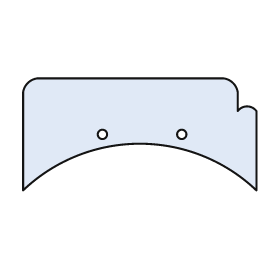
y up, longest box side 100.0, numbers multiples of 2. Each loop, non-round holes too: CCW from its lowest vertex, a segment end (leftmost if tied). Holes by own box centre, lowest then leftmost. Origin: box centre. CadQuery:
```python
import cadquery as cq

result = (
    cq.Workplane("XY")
    .moveTo(-50.0, -24.0)
    .threePointArc((0.0, -4.0), (50.0, -24.0))
    .lineTo(50.0, 10.0)
    .threePointArc((46.0, 12.0), (42.0, 10.0))
    .lineTo(42.0, 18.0)
    .threePointArc((40.0, 22.0), (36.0, 24.0))
    .lineTo(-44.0, 24.0)
    .threePointArc((-48.0, 22.0), (-50.0, 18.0))
    .close()
    .moveTo(-16.0, 0.0)
    .circle(2.0)
    .moveTo(18.0, 0.0)
    .circle(2.0)
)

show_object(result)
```